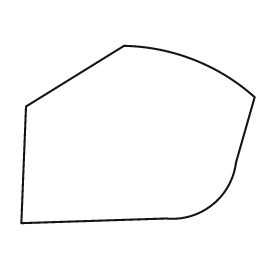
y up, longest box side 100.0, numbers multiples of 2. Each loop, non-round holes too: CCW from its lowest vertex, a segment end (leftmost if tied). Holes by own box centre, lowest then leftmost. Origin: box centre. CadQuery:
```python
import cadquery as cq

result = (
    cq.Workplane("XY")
    .moveTo(-50.0, -38.0)
    .lineTo(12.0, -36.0)
    .threePointArc((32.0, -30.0), (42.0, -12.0))
    .lineTo(50.0, 16.0)
    .threePointArc((24.0, 32.0), (-6.0, 38.0))
    .lineTo(-48.0, 12.0)
    .close()
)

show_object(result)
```